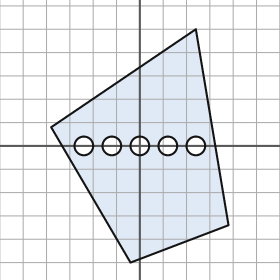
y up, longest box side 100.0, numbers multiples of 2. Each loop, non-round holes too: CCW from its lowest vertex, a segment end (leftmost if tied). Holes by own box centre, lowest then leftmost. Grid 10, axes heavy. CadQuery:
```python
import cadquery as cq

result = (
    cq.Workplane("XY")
    .moveTo(-4.0, -50.0)
    .lineTo(38.0, -34.0)
    .lineTo(24.0, 50.0)
    .lineTo(-38.0, 8.0)
    .close()
    .moveTo(-24.0, 0.0)
    .circle(4.0)
    .moveTo(-12.0, 0.0)
    .circle(4.0)
    .moveTo(0.0, 0.0)
    .circle(4.0)
    .moveTo(12.0, 0.0)
    .circle(4.0)
    .moveTo(24.0, 0.0)
    .circle(4.0)
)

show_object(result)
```